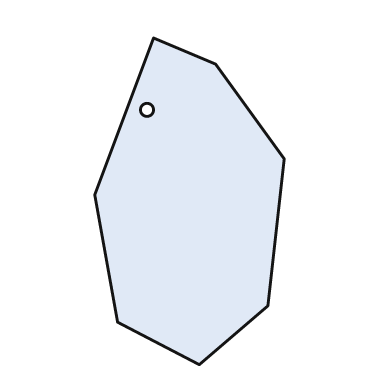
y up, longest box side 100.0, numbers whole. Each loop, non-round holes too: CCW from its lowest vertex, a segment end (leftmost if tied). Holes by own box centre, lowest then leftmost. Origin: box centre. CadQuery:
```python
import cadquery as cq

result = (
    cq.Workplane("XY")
    .moveTo(3.0, -50.0)
    .lineTo(24.0, -32.0)
    .lineTo(29.0, 13.0)
    .lineTo(8.0, 42.0)
    .lineTo(-11.0, 50.0)
    .lineTo(-29.0, 2.0)
    .lineTo(-22.0, -37.0)
    .close()
    .moveTo(-13.0, 28.0)
    .circle(2.0)
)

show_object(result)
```